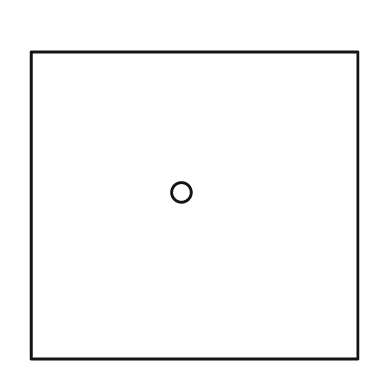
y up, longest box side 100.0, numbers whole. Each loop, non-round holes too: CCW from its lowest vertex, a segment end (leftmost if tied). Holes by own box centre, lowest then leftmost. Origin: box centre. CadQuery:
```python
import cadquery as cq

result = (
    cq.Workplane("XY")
    .moveTo(-50.0, -47.0)
    .lineTo(50.0, -47.0)
    .lineTo(50.0, 47.0)
    .lineTo(-50.0, 47.0)
    .close()
    .moveTo(-4.0, 4.0)
    .circle(3.0)
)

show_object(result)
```